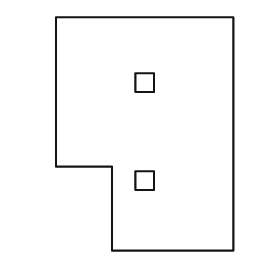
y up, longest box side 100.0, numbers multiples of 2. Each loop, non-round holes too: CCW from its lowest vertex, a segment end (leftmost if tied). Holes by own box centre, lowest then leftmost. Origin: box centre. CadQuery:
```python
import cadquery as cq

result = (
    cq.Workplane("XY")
    .moveTo(-14.0, -50.0)
    .lineTo(38.0, -50.0)
    .lineTo(38.0, 50.0)
    .lineTo(-38.0, 50.0)
    .lineTo(-38.0, -14.0)
    .lineTo(-14.0, -14.0)
    .close()
    .moveTo(-4.0, -24.0)
    .lineTo(4.0, -24.0)
    .lineTo(4.0, -16.0)
    .lineTo(-4.0, -16.0)
    .close()
    .moveTo(-4.0, 18.0)
    .lineTo(4.0, 18.0)
    .lineTo(4.0, 26.0)
    .lineTo(-4.0, 26.0)
    .close()
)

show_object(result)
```